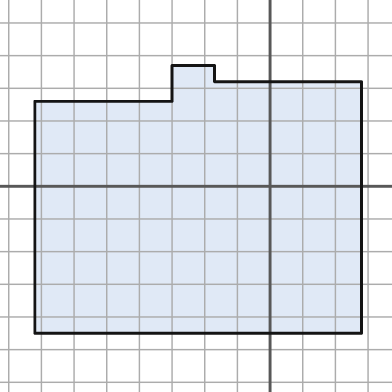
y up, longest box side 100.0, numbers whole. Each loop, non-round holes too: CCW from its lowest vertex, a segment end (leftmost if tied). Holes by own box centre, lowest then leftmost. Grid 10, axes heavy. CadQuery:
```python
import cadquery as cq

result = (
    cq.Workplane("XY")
    .moveTo(-72.0, -45.0)
    .lineTo(28.0, -45.0)
    .lineTo(28.0, 32.0)
    .lineTo(-17.0, 32.0)
    .lineTo(-17.0, 37.0)
    .lineTo(-30.0, 37.0)
    .lineTo(-30.0, 26.0)
    .lineTo(-72.0, 26.0)
    .close()
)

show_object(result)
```